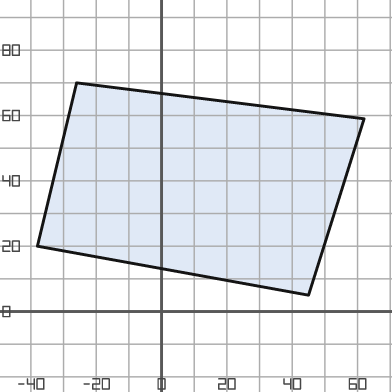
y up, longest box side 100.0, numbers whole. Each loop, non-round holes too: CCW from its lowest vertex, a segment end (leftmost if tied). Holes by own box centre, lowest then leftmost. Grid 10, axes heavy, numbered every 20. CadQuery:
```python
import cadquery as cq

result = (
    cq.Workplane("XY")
    .moveTo(45.0, 5.0)
    .lineTo(62.0, 59.0)
    .lineTo(-26.0, 70.0)
    .lineTo(-38.0, 20.0)
    .close()
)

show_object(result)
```